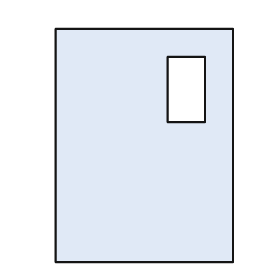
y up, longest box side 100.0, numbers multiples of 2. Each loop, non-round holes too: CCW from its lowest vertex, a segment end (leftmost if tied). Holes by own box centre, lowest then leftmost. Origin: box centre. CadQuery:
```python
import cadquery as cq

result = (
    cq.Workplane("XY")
    .moveTo(-38.0, -50.0)
    .lineTo(38.0, -50.0)
    .lineTo(38.0, 50.0)
    .lineTo(-38.0, 50.0)
    .close()
    .moveTo(10.0, 10.0)
    .lineTo(26.0, 10.0)
    .lineTo(26.0, 38.0)
    .lineTo(10.0, 38.0)
    .close()
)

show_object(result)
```